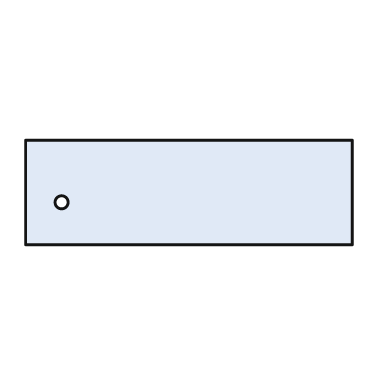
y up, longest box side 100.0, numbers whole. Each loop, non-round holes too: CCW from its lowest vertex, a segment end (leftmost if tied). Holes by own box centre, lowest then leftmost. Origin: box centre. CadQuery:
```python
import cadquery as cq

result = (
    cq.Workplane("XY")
    .moveTo(-50.0, -16.0)
    .lineTo(50.0, -16.0)
    .lineTo(50.0, 16.0)
    .lineTo(-50.0, 16.0)
    .close()
    .moveTo(-39.0, -3.0)
    .circle(2.0)
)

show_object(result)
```